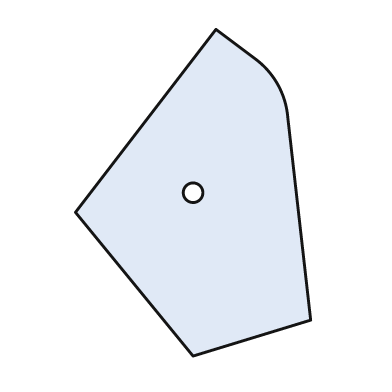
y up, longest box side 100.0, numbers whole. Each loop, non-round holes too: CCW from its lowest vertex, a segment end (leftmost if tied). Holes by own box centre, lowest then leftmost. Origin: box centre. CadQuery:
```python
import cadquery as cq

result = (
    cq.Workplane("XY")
    .moveTo(0.0, -50.0)
    .lineTo(36.0, -39.0)
    .lineTo(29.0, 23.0)
    .threePointArc((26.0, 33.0), (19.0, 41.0))
    .lineTo(7.0, 50.0)
    .lineTo(-36.0, -6.0)
    .close()
    .moveTo(0.0, 0.0)
    .circle(3.0)
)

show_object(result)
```